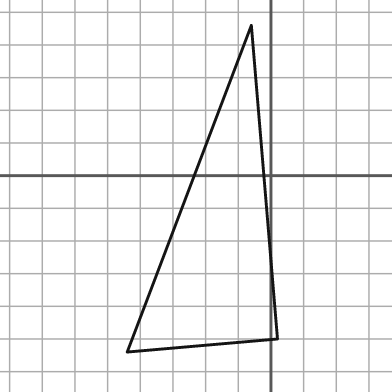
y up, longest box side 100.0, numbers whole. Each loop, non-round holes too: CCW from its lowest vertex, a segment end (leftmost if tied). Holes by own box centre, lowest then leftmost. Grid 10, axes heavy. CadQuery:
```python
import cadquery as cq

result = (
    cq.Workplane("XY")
    .moveTo(-44.0, -54.0)
    .lineTo(2.0, -50.0)
    .lineTo(-6.0, 46.0)
    .close()
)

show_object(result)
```